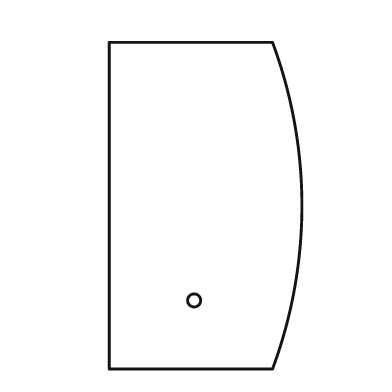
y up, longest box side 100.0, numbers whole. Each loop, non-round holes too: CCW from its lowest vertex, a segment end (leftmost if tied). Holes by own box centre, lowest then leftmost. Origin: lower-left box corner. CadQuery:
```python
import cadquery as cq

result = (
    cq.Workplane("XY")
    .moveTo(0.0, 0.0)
    .lineTo(50.0, 0.0)
    .threePointArc((59.0, 50.0), (50.0, 100.0))
    .lineTo(0.0, 100.0)
    .close()
    .moveTo(26.0, 21.0)
    .circle(2.0)
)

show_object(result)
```